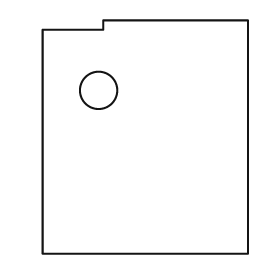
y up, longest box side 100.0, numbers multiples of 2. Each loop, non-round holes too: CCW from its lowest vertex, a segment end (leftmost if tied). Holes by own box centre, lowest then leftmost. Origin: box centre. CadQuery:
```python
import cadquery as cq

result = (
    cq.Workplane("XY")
    .moveTo(-44.0, -50.0)
    .lineTo(44.0, -50.0)
    .lineTo(44.0, 50.0)
    .lineTo(-18.0, 50.0)
    .lineTo(-18.0, 46.0)
    .lineTo(-44.0, 46.0)
    .close()
    .moveTo(-20.0, 20.0)
    .circle(8.0)
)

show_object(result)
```